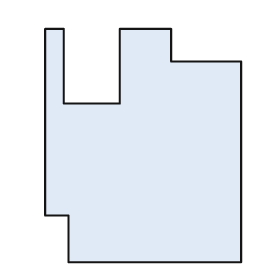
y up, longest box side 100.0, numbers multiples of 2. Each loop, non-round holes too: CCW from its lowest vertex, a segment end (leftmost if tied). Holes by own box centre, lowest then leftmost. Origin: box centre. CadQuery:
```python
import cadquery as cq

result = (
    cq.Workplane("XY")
    .moveTo(-32.0, -50.0)
    .lineTo(42.0, -50.0)
    .lineTo(42.0, 36.0)
    .lineTo(12.0, 36.0)
    .lineTo(12.0, 50.0)
    .lineTo(-10.0, 50.0)
    .lineTo(-10.0, 18.0)
    .lineTo(-34.0, 18.0)
    .lineTo(-34.0, 50.0)
    .lineTo(-42.0, 50.0)
    .lineTo(-42.0, -30.0)
    .lineTo(-32.0, -30.0)
    .close()
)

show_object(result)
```